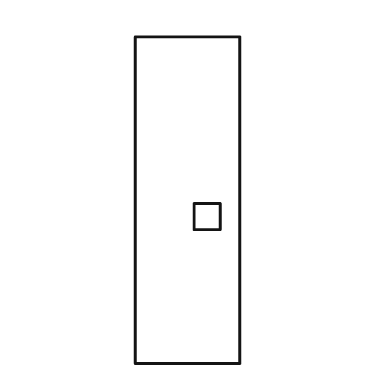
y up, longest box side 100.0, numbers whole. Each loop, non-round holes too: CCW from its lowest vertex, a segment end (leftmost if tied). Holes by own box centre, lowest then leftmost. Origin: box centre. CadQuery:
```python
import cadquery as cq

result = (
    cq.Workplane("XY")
    .moveTo(-16.0, -50.0)
    .lineTo(16.0, -50.0)
    .lineTo(16.0, 50.0)
    .lineTo(-16.0, 50.0)
    .close()
    .moveTo(2.0, -9.0)
    .lineTo(10.0, -9.0)
    .lineTo(10.0, -1.0)
    .lineTo(2.0, -1.0)
    .close()
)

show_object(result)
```